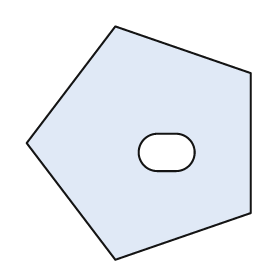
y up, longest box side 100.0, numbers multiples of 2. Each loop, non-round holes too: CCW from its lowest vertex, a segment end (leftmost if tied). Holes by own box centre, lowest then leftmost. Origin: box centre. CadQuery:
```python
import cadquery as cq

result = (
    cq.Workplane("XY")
    .moveTo(-10.0, -50.0)
    .lineTo(48.0, -30.0)
    .lineTo(48.0, 30.0)
    .lineTo(-10.0, 50.0)
    .lineTo(-48.0, 0.0)
    .close()
    .moveTo(8.0, -12.0)
    .lineTo(16.0, -12.0)
    .threePointArc((24.0, -4.0), (16.0, 4.0))
    .lineTo(8.0, 4.0)
    .threePointArc((0.0, -4.0), (8.0, -12.0))
    .close()
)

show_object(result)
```